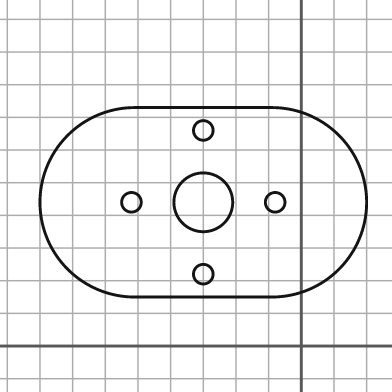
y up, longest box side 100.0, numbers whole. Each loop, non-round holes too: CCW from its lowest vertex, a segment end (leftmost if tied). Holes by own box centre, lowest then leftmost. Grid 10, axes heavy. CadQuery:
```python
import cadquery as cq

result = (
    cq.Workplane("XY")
    .moveTo(-51.0, 15.0)
    .lineTo(-9.0, 15.0)
    .threePointArc((20.0, 44.0), (-9.0, 73.0))
    .lineTo(-51.0, 73.0)
    .threePointArc((-80.0, 44.0), (-51.0, 15.0))
    .close()
    .moveTo(-30.0, 22.0)
    .circle(3.0)
    .moveTo(-52.0, 44.0)
    .circle(3.0)
    .moveTo(-30.0, 44.0)
    .circle(9.0)
    .moveTo(-8.0, 44.0)
    .circle(3.0)
    .moveTo(-30.0, 66.0)
    .circle(3.0)
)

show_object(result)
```